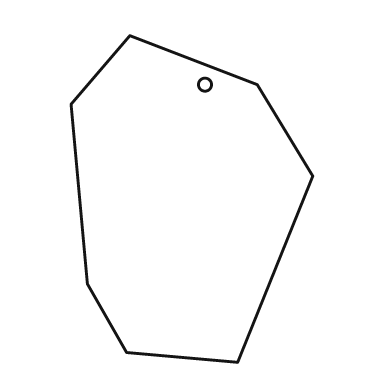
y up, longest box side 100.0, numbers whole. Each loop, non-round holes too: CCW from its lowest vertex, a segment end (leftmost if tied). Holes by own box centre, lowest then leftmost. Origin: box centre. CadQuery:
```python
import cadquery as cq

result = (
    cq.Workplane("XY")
    .moveTo(14.0, -50.0)
    .lineTo(37.0, 7.0)
    .lineTo(20.0, 35.0)
    .lineTo(-19.0, 50.0)
    .lineTo(-37.0, 29.0)
    .lineTo(-32.0, -26.0)
    .lineTo(-20.0, -47.0)
    .close()
    .moveTo(4.0, 35.0)
    .circle(2.0)
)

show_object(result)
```